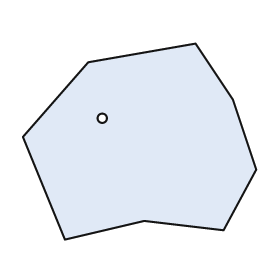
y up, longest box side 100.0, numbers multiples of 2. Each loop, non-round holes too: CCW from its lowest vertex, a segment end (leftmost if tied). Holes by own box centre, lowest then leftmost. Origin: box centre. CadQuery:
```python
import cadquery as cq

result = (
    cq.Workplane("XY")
    .moveTo(-32.0, -42.0)
    .lineTo(2.0, -34.0)
    .lineTo(36.0, -38.0)
    .lineTo(50.0, -12.0)
    .lineTo(40.0, 18.0)
    .lineTo(24.0, 42.0)
    .lineTo(-22.0, 34.0)
    .lineTo(-50.0, 2.0)
    .close()
    .moveTo(-16.0, 10.0)
    .circle(2.0)
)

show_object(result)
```